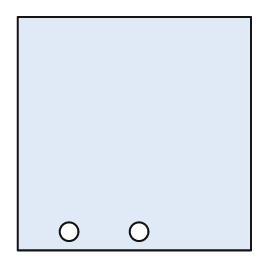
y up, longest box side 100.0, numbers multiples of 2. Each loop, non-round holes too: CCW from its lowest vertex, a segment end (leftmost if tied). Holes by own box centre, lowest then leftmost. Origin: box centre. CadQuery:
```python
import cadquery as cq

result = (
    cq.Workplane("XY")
    .moveTo(-50.0, -50.0)
    .lineTo(50.0, -50.0)
    .lineTo(50.0, 50.0)
    .lineTo(-50.0, 50.0)
    .close()
    .moveTo(-28.0, -42.0)
    .circle(4.0)
    .moveTo(2.0, -42.0)
    .circle(4.0)
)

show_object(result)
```